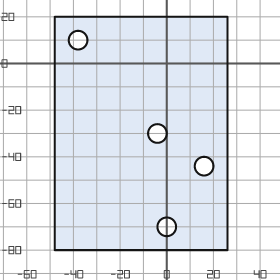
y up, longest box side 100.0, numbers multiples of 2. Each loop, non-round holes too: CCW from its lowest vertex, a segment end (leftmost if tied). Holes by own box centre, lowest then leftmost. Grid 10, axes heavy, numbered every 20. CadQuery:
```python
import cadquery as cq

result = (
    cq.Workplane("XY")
    .moveTo(-48.0, -80.0)
    .lineTo(26.0, -80.0)
    .lineTo(26.0, 20.0)
    .lineTo(-48.0, 20.0)
    .close()
    .moveTo(0.0, -70.0)
    .circle(4.0)
    .moveTo(16.0, -44.0)
    .circle(4.0)
    .moveTo(-4.0, -30.0)
    .circle(4.0)
    .moveTo(-38.0, 10.0)
    .circle(4.0)
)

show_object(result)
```